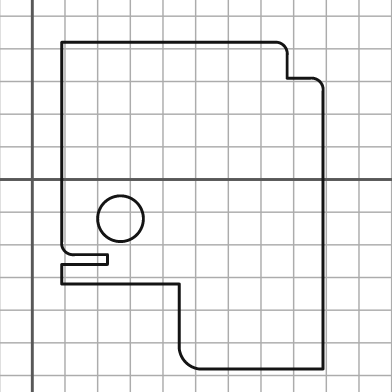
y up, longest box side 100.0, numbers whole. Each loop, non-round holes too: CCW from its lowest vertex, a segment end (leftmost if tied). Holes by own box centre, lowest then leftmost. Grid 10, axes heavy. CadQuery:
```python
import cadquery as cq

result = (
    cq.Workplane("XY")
    .moveTo(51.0, -58.0)
    .lineTo(89.0, -58.0)
    .lineTo(89.0, 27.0)
    .threePointArc((88.0, 30.0), (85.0, 31.0))
    .lineTo(78.0, 31.0)
    .lineTo(78.0, 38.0)
    .threePointArc((77.0, 41.0), (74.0, 42.0))
    .lineTo(9.0, 42.0)
    .lineTo(9.0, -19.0)
    .threePointArc((10.0, -22.0), (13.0, -23.0))
    .lineTo(23.0, -23.0)
    .lineTo(23.0, -26.0)
    .lineTo(9.0, -26.0)
    .lineTo(9.0, -32.0)
    .lineTo(45.0, -32.0)
    .lineTo(45.0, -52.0)
    .threePointArc((47.0, -56.0), (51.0, -58.0))
    .close()
    .moveTo(27.0, -12.0)
    .circle(7.0)
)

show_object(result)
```